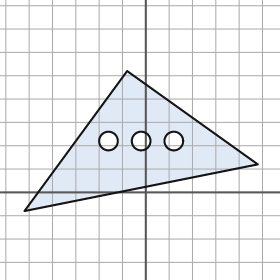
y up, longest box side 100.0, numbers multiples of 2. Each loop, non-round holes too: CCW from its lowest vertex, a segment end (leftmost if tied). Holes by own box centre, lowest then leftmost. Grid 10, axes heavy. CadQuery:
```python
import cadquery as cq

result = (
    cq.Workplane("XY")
    .moveTo(-52.0, -8.0)
    .lineTo(48.0, 12.0)
    .lineTo(-8.0, 52.0)
    .close()
    .moveTo(-16.0, 22.0)
    .circle(4.0)
    .moveTo(-2.0, 22.0)
    .circle(4.0)
    .moveTo(12.0, 22.0)
    .circle(4.0)
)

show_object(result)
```